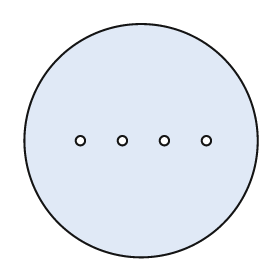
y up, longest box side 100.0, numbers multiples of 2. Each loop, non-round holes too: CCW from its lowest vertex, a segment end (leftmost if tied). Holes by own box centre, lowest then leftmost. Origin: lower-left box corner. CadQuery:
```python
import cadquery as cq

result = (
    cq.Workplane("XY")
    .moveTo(50.0, 50.0)
    .circle(50.0)
    .moveTo(24.0, 50.0)
    .circle(2.0)
    .moveTo(42.0, 50.0)
    .circle(2.0)
    .moveTo(60.0, 50.0)
    .circle(2.0)
    .moveTo(78.0, 50.0)
    .circle(2.0)
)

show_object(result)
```